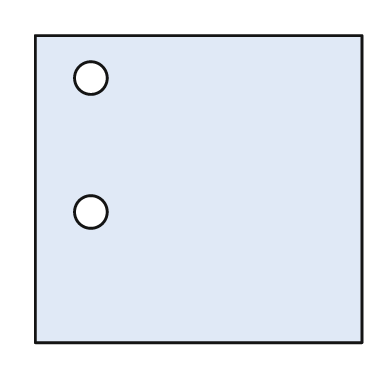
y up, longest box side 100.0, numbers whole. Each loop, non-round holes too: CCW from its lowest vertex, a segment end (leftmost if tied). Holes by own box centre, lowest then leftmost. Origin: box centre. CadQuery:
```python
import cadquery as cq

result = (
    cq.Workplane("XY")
    .moveTo(-50.0, -47.0)
    .lineTo(50.0, -47.0)
    .lineTo(50.0, 47.0)
    .lineTo(-50.0, 47.0)
    .close()
    .moveTo(-33.0, -7.0)
    .circle(5.0)
    .moveTo(-33.0, 34.0)
    .circle(5.0)
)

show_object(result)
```